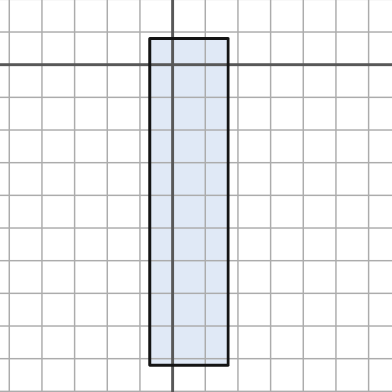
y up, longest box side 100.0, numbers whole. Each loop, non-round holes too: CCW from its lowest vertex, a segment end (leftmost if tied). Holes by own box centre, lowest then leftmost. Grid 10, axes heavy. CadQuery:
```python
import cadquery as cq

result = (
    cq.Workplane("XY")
    .moveTo(-7.0, -92.0)
    .lineTo(17.0, -92.0)
    .lineTo(17.0, 8.0)
    .lineTo(-7.0, 8.0)
    .close()
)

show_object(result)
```